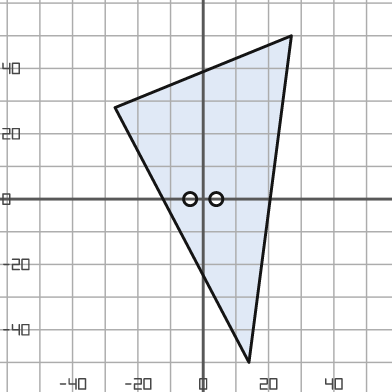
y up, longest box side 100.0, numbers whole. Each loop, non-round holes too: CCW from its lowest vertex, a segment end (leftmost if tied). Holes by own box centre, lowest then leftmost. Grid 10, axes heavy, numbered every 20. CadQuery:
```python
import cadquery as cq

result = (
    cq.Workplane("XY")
    .moveTo(14.0, -50.0)
    .lineTo(27.0, 50.0)
    .lineTo(-27.0, 28.0)
    .close()
    .moveTo(-4.0, 0.0)
    .circle(2.0)
    .moveTo(4.0, 0.0)
    .circle(2.0)
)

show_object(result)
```